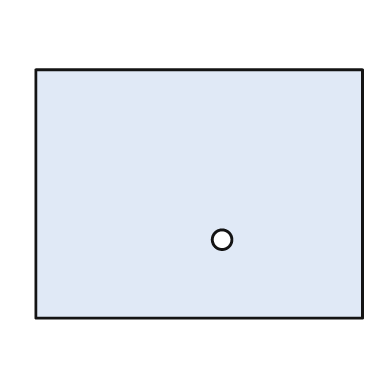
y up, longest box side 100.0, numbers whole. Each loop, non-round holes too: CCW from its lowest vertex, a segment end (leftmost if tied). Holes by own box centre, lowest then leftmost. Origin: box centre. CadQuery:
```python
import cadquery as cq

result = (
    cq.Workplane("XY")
    .moveTo(-50.0, -38.0)
    .lineTo(50.0, -38.0)
    .lineTo(50.0, 38.0)
    .lineTo(-50.0, 38.0)
    .close()
    .moveTo(7.0, -14.0)
    .circle(3.0)
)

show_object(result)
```